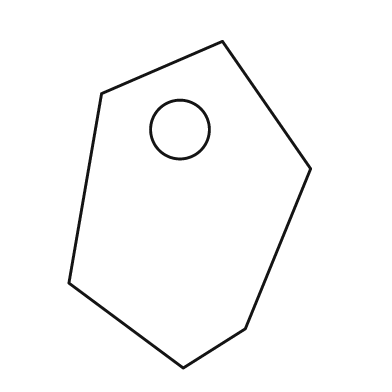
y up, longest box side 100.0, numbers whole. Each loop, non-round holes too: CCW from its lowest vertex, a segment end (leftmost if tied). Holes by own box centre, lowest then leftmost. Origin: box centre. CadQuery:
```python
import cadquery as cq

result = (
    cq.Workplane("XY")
    .moveTo(-2.0, -50.0)
    .lineTo(17.0, -38.0)
    .lineTo(37.0, 11.0)
    .lineTo(10.0, 50.0)
    .lineTo(-27.0, 34.0)
    .lineTo(-37.0, -24.0)
    .close()
    .moveTo(-3.0, 23.0)
    .circle(9.0)
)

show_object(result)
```